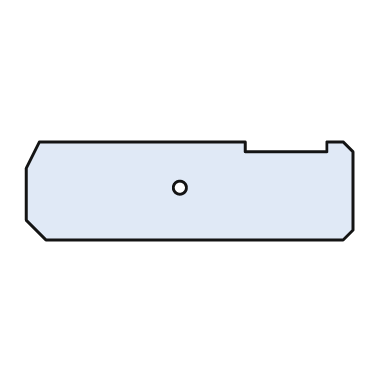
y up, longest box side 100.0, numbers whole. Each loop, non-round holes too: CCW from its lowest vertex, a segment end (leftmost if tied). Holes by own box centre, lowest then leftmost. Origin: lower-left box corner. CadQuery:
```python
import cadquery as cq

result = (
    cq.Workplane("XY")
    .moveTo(6.0, 0.0)
    .lineTo(97.0, 0.0)
    .lineTo(100.0, 3.0)
    .lineTo(100.0, 27.0)
    .lineTo(97.0, 30.0)
    .lineTo(92.0, 30.0)
    .lineTo(92.0, 27.0)
    .lineTo(67.0, 27.0)
    .lineTo(67.0, 30.0)
    .lineTo(4.0, 30.0)
    .lineTo(0.0, 22.0)
    .lineTo(0.0, 6.0)
    .close()
    .moveTo(47.0, 16.0)
    .circle(2.0)
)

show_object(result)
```